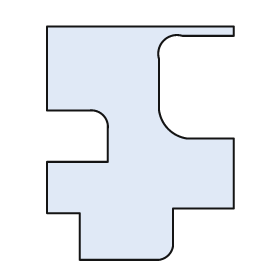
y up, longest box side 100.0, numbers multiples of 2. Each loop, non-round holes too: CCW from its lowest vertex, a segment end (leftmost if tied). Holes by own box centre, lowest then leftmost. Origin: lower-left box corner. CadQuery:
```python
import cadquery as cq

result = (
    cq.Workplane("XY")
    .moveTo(14.0, 0.0)
    .lineTo(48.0, 0.0)
    .threePointArc((52.0, 2.0), (54.0, 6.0))
    .lineTo(54.0, 22.0)
    .lineTo(80.0, 22.0)
    .lineTo(80.0, 52.0)
    .lineTo(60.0, 52.0)
    .threePointArc((52.0, 56.0), (48.0, 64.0))
    .lineTo(48.0, 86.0)
    .threePointArc((50.0, 94.0), (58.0, 96.0))
    .lineTo(80.0, 96.0)
    .lineTo(80.0, 100.0)
    .lineTo(0.0, 100.0)
    .lineTo(0.0, 64.0)
    .lineTo(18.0, 64.0)
    .threePointArc((24.0, 62.0), (26.0, 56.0))
    .lineTo(26.0, 42.0)
    .lineTo(0.0, 42.0)
    .lineTo(0.0, 20.0)
    .lineTo(14.0, 20.0)
    .close()
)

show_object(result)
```